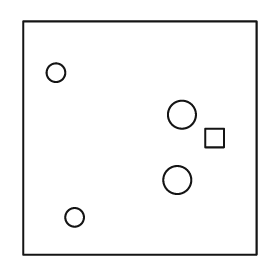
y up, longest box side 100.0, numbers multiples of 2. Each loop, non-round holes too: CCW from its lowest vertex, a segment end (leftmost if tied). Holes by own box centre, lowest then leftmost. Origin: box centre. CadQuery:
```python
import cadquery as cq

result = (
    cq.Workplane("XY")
    .moveTo(-50.0, -50.0)
    .lineTo(50.0, -50.0)
    .lineTo(50.0, 50.0)
    .lineTo(-50.0, 50.0)
    .close()
    .moveTo(-28.0, -34.0)
    .circle(4.0)
    .moveTo(16.0, -18.0)
    .circle(6.0)
    .moveTo(28.0, -4.0)
    .lineTo(36.0, -4.0)
    .lineTo(36.0, 4.0)
    .lineTo(28.0, 4.0)
    .close()
    .moveTo(18.0, 10.0)
    .circle(6.0)
    .moveTo(-36.0, 28.0)
    .circle(4.0)
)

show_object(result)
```